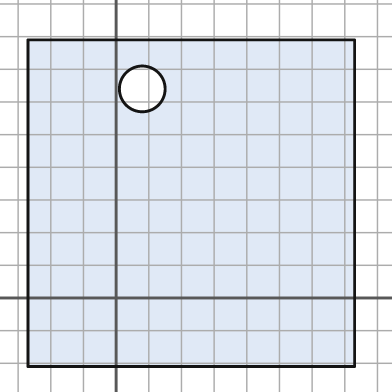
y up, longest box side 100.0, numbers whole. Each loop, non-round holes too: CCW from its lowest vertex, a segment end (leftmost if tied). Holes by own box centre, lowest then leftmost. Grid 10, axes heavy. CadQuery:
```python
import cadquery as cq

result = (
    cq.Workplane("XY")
    .moveTo(-27.0, -21.0)
    .lineTo(73.0, -21.0)
    .lineTo(73.0, 79.0)
    .lineTo(-27.0, 79.0)
    .close()
    .moveTo(8.0, 64.0)
    .circle(7.0)
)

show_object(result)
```